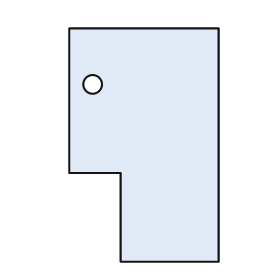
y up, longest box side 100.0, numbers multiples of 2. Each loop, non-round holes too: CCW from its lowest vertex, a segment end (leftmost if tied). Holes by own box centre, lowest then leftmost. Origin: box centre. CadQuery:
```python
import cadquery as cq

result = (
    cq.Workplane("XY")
    .moveTo(-10.0, -50.0)
    .lineTo(32.0, -50.0)
    .lineTo(32.0, 50.0)
    .lineTo(-32.0, 50.0)
    .lineTo(-32.0, -12.0)
    .lineTo(-10.0, -12.0)
    .close()
    .moveTo(-22.0, 26.0)
    .circle(4.0)
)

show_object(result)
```